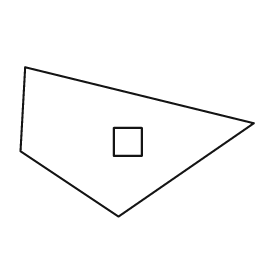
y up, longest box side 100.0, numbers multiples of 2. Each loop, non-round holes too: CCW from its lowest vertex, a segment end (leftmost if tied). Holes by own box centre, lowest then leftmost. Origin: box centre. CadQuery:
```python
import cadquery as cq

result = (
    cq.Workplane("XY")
    .moveTo(-8.0, -32.0)
    .lineTo(50.0, 8.0)
    .lineTo(-48.0, 32.0)
    .lineTo(-50.0, -4.0)
    .close()
    .moveTo(-10.0, -6.0)
    .lineTo(2.0, -6.0)
    .lineTo(2.0, 6.0)
    .lineTo(-10.0, 6.0)
    .close()
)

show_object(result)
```